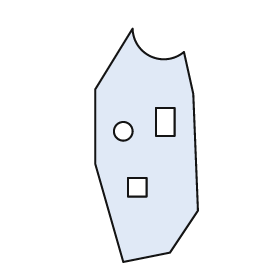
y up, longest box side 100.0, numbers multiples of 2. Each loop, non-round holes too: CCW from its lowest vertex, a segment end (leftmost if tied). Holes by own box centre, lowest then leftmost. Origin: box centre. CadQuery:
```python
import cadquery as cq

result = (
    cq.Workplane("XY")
    .moveTo(-10.0, -50.0)
    .lineTo(10.0, -46.0)
    .lineTo(22.0, -28.0)
    .lineTo(20.0, 22.0)
    .lineTo(16.0, 40.0)
    .threePointArc((2.0, 38.0), (-6.0, 50.0))
    .lineTo(-22.0, 24.0)
    .lineTo(-22.0, -8.0)
    .close()
    .moveTo(-8.0, -22.0)
    .lineTo(0.0, -22.0)
    .lineTo(0.0, -14.0)
    .lineTo(-8.0, -14.0)
    .close()
    .moveTo(-10.0, 6.0)
    .circle(4.0)
    .moveTo(4.0, 4.0)
    .lineTo(12.0, 4.0)
    .lineTo(12.0, 16.0)
    .lineTo(4.0, 16.0)
    .close()
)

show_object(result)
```